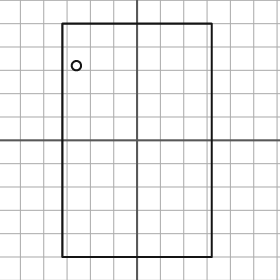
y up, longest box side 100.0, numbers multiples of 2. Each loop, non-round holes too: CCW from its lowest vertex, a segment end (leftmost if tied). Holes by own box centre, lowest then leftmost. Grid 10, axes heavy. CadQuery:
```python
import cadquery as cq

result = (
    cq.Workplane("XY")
    .moveTo(-32.0, -50.0)
    .lineTo(32.0, -50.0)
    .lineTo(32.0, 50.0)
    .lineTo(-32.0, 50.0)
    .close()
    .moveTo(-26.0, 32.0)
    .circle(2.0)
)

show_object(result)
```